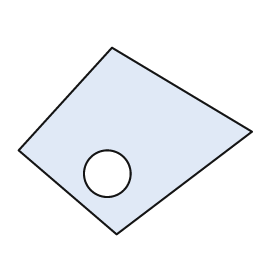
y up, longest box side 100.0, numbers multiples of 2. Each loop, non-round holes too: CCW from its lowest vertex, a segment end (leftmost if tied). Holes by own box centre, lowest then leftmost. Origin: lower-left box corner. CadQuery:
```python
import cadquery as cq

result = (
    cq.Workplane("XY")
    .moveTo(42.0, 0.0)
    .lineTo(100.0, 44.0)
    .lineTo(40.0, 80.0)
    .lineTo(0.0, 36.0)
    .close()
    .moveTo(38.0, 26.0)
    .circle(10.0)
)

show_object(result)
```